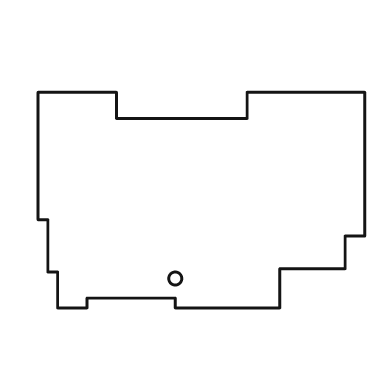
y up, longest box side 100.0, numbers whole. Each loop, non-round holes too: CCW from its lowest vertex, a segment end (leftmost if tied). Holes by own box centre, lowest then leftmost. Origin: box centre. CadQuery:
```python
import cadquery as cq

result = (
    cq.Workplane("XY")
    .moveTo(-44.0, -33.0)
    .lineTo(-35.0, -33.0)
    .lineTo(-35.0, -30.0)
    .lineTo(-8.0, -30.0)
    .lineTo(-8.0, -33.0)
    .lineTo(24.0, -33.0)
    .lineTo(24.0, -21.0)
    .lineTo(44.0, -21.0)
    .lineTo(44.0, -11.0)
    .lineTo(50.0, -11.0)
    .lineTo(50.0, 33.0)
    .lineTo(14.0, 33.0)
    .lineTo(14.0, 25.0)
    .lineTo(-26.0, 25.0)
    .lineTo(-26.0, 33.0)
    .lineTo(-50.0, 33.0)
    .lineTo(-50.0, -6.0)
    .lineTo(-47.0, -6.0)
    .lineTo(-47.0, -22.0)
    .lineTo(-44.0, -22.0)
    .close()
    .moveTo(-8.0, -24.0)
    .circle(2.0)
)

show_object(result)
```